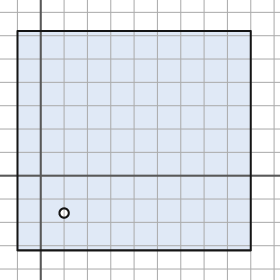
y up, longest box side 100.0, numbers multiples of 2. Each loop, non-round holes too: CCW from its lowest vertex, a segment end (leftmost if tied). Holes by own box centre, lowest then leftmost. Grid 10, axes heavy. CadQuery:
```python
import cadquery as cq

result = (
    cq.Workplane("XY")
    .moveTo(-10.0, -32.0)
    .lineTo(90.0, -32.0)
    .lineTo(90.0, 62.0)
    .lineTo(-10.0, 62.0)
    .close()
    .moveTo(10.0, -16.0)
    .circle(2.0)
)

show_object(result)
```